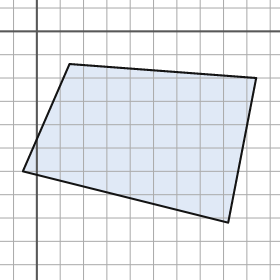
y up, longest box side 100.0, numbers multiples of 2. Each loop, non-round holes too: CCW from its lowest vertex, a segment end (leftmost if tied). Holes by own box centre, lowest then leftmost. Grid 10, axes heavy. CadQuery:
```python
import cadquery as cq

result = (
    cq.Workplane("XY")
    .moveTo(82.0, -82.0)
    .lineTo(94.0, -20.0)
    .lineTo(14.0, -14.0)
    .lineTo(-6.0, -60.0)
    .close()
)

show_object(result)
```